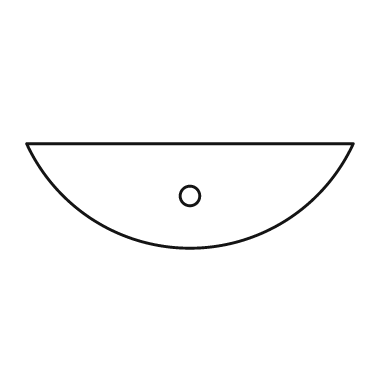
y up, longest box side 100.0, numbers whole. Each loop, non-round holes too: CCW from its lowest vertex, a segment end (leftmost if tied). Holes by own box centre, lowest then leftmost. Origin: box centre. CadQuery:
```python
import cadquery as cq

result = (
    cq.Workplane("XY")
    .moveTo(-50.0, 16.0)
    .threePointArc((0.0, -16.0), (50.0, 16.0))
    .close()
    .moveTo(0.0, 0.0)
    .circle(3.0)
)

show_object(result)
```